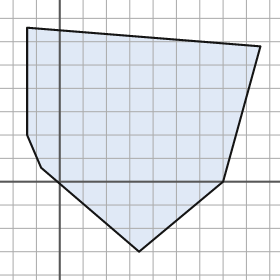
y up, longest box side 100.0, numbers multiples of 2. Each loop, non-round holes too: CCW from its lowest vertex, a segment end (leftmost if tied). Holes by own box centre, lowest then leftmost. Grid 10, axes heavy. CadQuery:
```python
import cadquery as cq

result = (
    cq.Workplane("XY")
    .moveTo(34.0, -30.0)
    .lineTo(70.0, 0.0)
    .lineTo(86.0, 58.0)
    .lineTo(-14.0, 66.0)
    .lineTo(-14.0, 20.0)
    .lineTo(-8.0, 6.0)
    .close()
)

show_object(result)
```